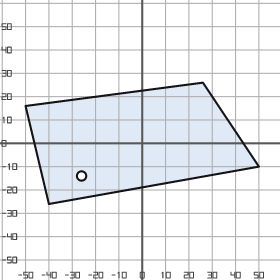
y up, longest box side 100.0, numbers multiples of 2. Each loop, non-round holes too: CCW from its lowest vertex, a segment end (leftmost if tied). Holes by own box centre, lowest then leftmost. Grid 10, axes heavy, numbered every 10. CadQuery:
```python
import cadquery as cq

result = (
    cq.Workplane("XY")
    .moveTo(-40.0, -26.0)
    .lineTo(50.0, -10.0)
    .lineTo(26.0, 26.0)
    .lineTo(-50.0, 16.0)
    .close()
    .moveTo(-26.0, -14.0)
    .circle(2.0)
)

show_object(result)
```